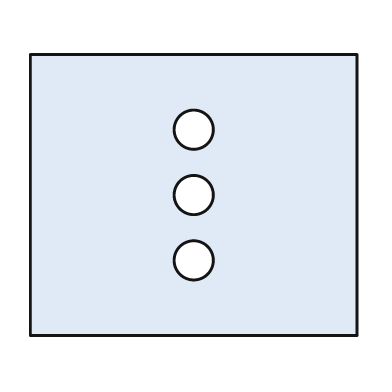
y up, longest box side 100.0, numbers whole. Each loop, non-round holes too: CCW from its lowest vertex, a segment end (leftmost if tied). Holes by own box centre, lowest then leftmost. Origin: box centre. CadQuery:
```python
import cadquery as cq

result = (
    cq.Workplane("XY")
    .moveTo(-50.0, -43.0)
    .lineTo(50.0, -43.0)
    .lineTo(50.0, 43.0)
    .lineTo(-50.0, 43.0)
    .close()
    .moveTo(0.0, -20.0)
    .circle(6.0)
    .moveTo(0.0, 0.0)
    .circle(6.0)
    .moveTo(0.0, 20.0)
    .circle(6.0)
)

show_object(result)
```